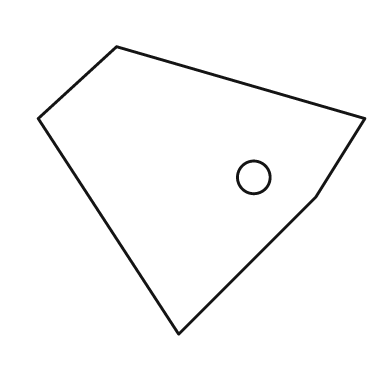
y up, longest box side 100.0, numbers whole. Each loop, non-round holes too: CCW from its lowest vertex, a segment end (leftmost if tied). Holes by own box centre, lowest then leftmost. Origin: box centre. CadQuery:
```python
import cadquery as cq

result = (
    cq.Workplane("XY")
    .moveTo(-7.0, -44.0)
    .lineTo(35.0, -2.0)
    .lineTo(50.0, 22.0)
    .lineTo(-26.0, 44.0)
    .lineTo(-50.0, 22.0)
    .close()
    .moveTo(16.0, 4.0)
    .circle(5.0)
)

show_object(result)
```